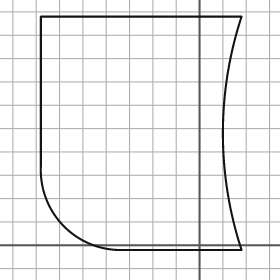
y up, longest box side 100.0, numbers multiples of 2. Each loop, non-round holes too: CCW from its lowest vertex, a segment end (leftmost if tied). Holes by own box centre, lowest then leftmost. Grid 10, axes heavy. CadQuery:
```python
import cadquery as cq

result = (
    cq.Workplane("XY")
    .moveTo(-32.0, -2.0)
    .lineTo(18.0, -2.0)
    .threePointArc((10.0, 48.0), (18.0, 98.0))
    .lineTo(-68.0, 98.0)
    .lineTo(-68.0, 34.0)
    .threePointArc((-58.0, 8.0), (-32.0, -2.0))
    .close()
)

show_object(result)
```